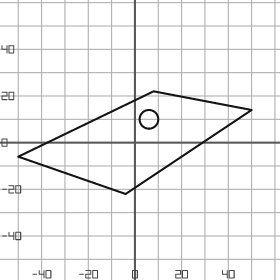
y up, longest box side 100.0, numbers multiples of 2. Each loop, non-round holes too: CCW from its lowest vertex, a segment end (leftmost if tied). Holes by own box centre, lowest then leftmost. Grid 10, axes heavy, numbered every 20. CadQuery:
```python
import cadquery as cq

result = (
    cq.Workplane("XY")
    .moveTo(-4.0, -22.0)
    .lineTo(50.0, 14.0)
    .lineTo(8.0, 22.0)
    .lineTo(-50.0, -6.0)
    .close()
    .moveTo(6.0, 10.0)
    .circle(4.0)
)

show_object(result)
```